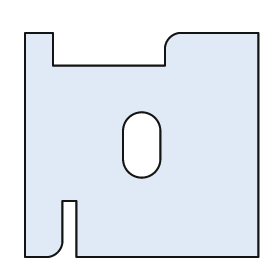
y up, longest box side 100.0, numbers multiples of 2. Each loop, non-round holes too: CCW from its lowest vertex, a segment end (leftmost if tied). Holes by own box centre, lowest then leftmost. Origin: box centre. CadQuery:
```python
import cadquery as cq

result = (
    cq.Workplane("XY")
    .moveTo(-50.0, -48.0)
    .lineTo(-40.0, -48.0)
    .threePointArc((-36.0, -46.0), (-34.0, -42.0))
    .lineTo(-34.0, -24.0)
    .lineTo(-28.0, -24.0)
    .lineTo(-28.0, -48.0)
    .lineTo(50.0, -48.0)
    .lineTo(50.0, 48.0)
    .lineTo(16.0, 48.0)
    .threePointArc((12.0, 46.0), (10.0, 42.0))
    .lineTo(10.0, 34.0)
    .lineTo(-38.0, 34.0)
    .lineTo(-38.0, 48.0)
    .lineTo(-50.0, 48.0)
    .close()
    .moveTo(-8.0, -6.0)
    .threePointArc((0.0, -14.0), (8.0, -6.0))
    .lineTo(8.0, 6.0)
    .threePointArc((0.0, 14.0), (-8.0, 6.0))
    .close()
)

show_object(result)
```